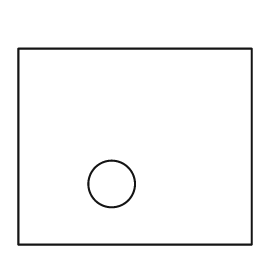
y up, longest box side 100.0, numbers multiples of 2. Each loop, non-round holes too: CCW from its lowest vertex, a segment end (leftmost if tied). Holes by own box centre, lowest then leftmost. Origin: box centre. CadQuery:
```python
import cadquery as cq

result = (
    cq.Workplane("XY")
    .moveTo(-50.0, -42.0)
    .lineTo(50.0, -42.0)
    .lineTo(50.0, 42.0)
    .lineTo(-50.0, 42.0)
    .close()
    .moveTo(-10.0, -16.0)
    .circle(10.0)
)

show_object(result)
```